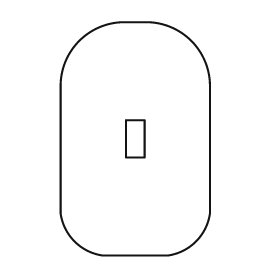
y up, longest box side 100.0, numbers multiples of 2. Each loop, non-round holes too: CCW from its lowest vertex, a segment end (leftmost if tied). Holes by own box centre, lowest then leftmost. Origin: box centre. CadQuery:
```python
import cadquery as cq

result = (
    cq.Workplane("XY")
    .moveTo(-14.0, -50.0)
    .lineTo(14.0, -50.0)
    .threePointArc((26.0, -44.0), (32.0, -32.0))
    .lineTo(32.0, 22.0)
    .threePointArc((24.0, 42.0), (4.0, 50.0))
    .lineTo(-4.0, 50.0)
    .threePointArc((-24.0, 42.0), (-32.0, 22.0))
    .lineTo(-32.0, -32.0)
    .threePointArc((-26.0, -44.0), (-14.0, -50.0))
    .close()
    .moveTo(-4.0, -8.0)
    .lineTo(4.0, -8.0)
    .lineTo(4.0, 8.0)
    .lineTo(-4.0, 8.0)
    .close()
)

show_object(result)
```